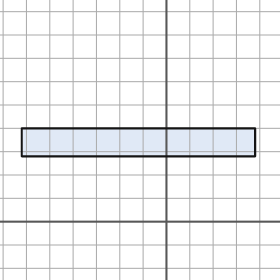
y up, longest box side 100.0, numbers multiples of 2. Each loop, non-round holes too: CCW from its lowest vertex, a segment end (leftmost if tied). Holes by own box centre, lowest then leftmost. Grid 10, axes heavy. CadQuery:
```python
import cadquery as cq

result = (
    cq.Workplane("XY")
    .moveTo(-62.0, 28.0)
    .lineTo(38.0, 28.0)
    .lineTo(38.0, 40.0)
    .lineTo(-62.0, 40.0)
    .close()
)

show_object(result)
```